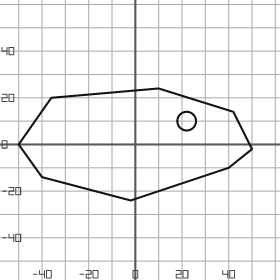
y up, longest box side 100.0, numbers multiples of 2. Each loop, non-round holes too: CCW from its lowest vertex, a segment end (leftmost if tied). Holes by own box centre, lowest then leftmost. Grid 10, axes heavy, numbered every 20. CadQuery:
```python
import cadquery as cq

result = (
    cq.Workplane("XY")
    .moveTo(-2.0, -24.0)
    .lineTo(40.0, -10.0)
    .lineTo(50.0, -2.0)
    .lineTo(42.0, 14.0)
    .lineTo(10.0, 24.0)
    .lineTo(-36.0, 20.0)
    .lineTo(-50.0, 0.0)
    .lineTo(-40.0, -14.0)
    .close()
    .moveTo(22.0, 10.0)
    .circle(4.0)
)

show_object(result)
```